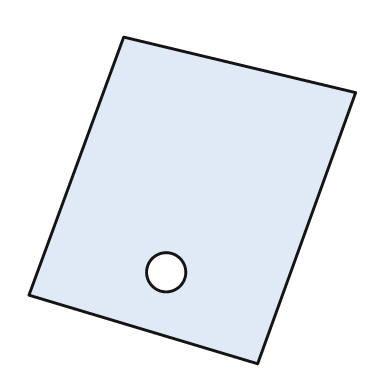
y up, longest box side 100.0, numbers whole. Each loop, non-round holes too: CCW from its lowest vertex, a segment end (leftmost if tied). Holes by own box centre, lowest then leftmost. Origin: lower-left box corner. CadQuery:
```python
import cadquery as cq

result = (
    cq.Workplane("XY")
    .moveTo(70.0, 0.0)
    .lineTo(100.0, 83.0)
    .lineTo(29.0, 100.0)
    .lineTo(0.0, 21.0)
    .close()
    .moveTo(42.0, 28.0)
    .circle(6.0)
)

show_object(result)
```